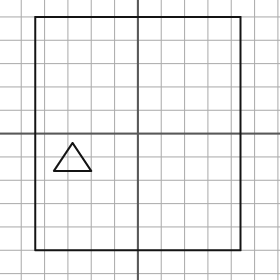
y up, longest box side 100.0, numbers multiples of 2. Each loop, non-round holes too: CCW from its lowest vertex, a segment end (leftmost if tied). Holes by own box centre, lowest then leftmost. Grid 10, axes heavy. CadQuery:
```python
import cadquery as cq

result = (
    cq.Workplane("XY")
    .moveTo(-44.0, -50.0)
    .lineTo(44.0, -50.0)
    .lineTo(44.0, 50.0)
    .lineTo(-44.0, 50.0)
    .close()
    .moveTo(-36.0, -16.0)
    .lineTo(-20.0, -16.0)
    .lineTo(-28.0, -4.0)
    .close()
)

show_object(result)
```